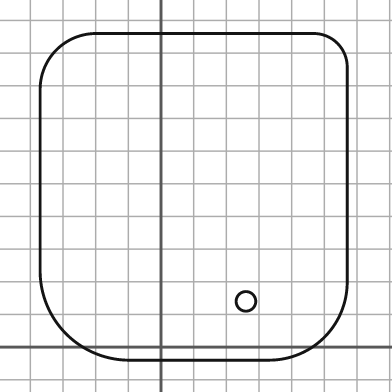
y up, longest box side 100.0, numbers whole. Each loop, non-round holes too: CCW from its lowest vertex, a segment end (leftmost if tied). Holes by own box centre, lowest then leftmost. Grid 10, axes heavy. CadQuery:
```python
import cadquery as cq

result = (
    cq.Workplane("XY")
    .moveTo(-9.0, -4.0)
    .lineTo(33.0, -4.0)
    .threePointArc((50.0, 3.0), (57.0, 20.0))
    .lineTo(57.0, 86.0)
    .threePointArc((54.0, 93.0), (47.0, 96.0))
    .lineTo(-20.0, 96.0)
    .threePointArc((-32.0, 91.0), (-37.0, 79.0))
    .lineTo(-37.0, 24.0)
    .threePointArc((-29.0, 4.0), (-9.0, -4.0))
    .close()
    .moveTo(26.0, 14.0)
    .circle(3.0)
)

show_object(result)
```